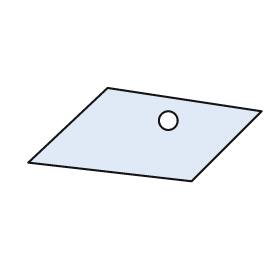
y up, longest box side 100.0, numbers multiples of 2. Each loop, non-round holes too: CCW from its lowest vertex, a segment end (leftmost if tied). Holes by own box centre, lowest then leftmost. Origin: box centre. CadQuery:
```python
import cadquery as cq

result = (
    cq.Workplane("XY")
    .moveTo(20.0, -20.0)
    .lineTo(50.0, 10.0)
    .lineTo(-16.0, 20.0)
    .lineTo(-50.0, -12.0)
    .close()
    .moveTo(10.0, 6.0)
    .circle(4.0)
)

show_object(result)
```